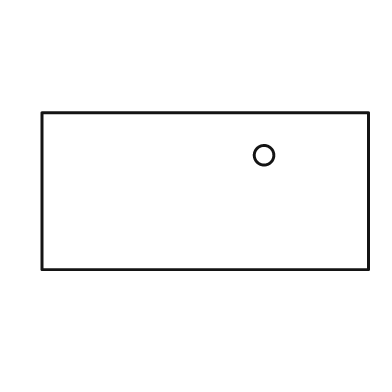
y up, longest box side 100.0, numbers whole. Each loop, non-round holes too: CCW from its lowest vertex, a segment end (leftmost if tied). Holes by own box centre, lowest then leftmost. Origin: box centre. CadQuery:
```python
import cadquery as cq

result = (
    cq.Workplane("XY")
    .moveTo(-50.0, -24.0)
    .lineTo(50.0, -24.0)
    .lineTo(50.0, 24.0)
    .lineTo(-50.0, 24.0)
    .close()
    .moveTo(18.0, 11.0)
    .circle(3.0)
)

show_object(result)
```